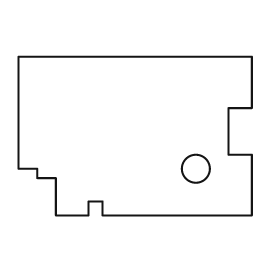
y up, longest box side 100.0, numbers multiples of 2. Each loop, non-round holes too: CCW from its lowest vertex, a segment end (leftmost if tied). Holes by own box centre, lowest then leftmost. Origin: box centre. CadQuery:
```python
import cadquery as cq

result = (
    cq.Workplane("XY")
    .moveTo(-34.0, -34.0)
    .lineTo(-20.0, -34.0)
    .lineTo(-20.0, -28.0)
    .lineTo(-14.0, -28.0)
    .lineTo(-14.0, -34.0)
    .lineTo(50.0, -34.0)
    .lineTo(50.0, -8.0)
    .lineTo(40.0, -8.0)
    .lineTo(40.0, 12.0)
    .lineTo(50.0, 12.0)
    .lineTo(50.0, 34.0)
    .lineTo(-50.0, 34.0)
    .lineTo(-50.0, -14.0)
    .lineTo(-42.0, -14.0)
    .lineTo(-42.0, -18.0)
    .lineTo(-34.0, -18.0)
    .close()
    .moveTo(26.0, -14.0)
    .circle(6.0)
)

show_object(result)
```